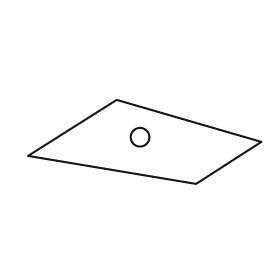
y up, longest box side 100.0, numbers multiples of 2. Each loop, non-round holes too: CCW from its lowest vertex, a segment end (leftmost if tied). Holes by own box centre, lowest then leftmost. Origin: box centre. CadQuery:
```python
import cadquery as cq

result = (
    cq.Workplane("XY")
    .moveTo(22.0, -18.0)
    .lineTo(50.0, 0.0)
    .lineTo(-12.0, 18.0)
    .lineTo(-50.0, -6.0)
    .close()
    .moveTo(-2.0, 2.0)
    .circle(4.0)
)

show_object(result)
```